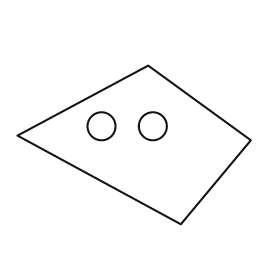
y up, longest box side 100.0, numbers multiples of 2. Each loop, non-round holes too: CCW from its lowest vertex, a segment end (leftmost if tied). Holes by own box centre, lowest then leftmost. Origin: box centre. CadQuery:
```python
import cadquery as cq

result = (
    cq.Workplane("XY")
    .moveTo(20.0, -34.0)
    .lineTo(50.0, 2.0)
    .lineTo(6.0, 34.0)
    .lineTo(-50.0, 4.0)
    .close()
    .moveTo(-14.0, 8.0)
    .circle(6.0)
    .moveTo(8.0, 8.0)
    .circle(6.0)
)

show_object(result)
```